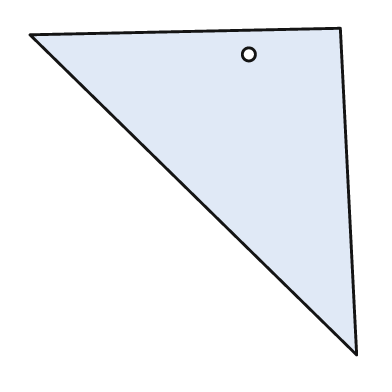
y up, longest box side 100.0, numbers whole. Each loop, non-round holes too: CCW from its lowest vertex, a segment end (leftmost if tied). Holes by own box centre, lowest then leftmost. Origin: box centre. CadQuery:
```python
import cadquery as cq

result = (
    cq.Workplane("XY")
    .moveTo(50.0, -50.0)
    .lineTo(45.0, 50.0)
    .lineTo(-50.0, 48.0)
    .close()
    .moveTo(17.0, 42.0)
    .circle(2.0)
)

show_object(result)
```